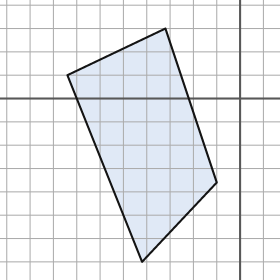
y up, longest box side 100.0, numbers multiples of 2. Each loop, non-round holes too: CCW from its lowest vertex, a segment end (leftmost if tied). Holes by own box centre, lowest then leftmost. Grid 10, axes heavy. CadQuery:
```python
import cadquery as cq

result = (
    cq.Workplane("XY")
    .moveTo(-42.0, -70.0)
    .lineTo(-10.0, -36.0)
    .lineTo(-32.0, 30.0)
    .lineTo(-74.0, 10.0)
    .close()
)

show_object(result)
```